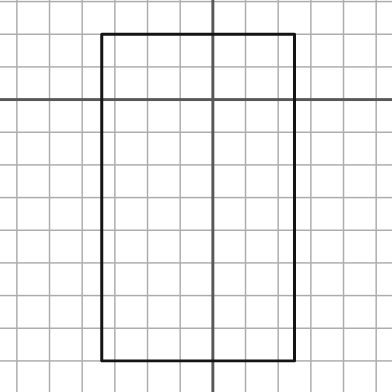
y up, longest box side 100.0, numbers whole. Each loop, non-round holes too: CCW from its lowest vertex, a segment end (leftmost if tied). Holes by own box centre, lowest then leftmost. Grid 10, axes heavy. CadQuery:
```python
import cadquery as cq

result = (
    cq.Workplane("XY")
    .moveTo(-34.0, -80.0)
    .lineTo(25.0, -80.0)
    .lineTo(25.0, 20.0)
    .lineTo(-34.0, 20.0)
    .close()
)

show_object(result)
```